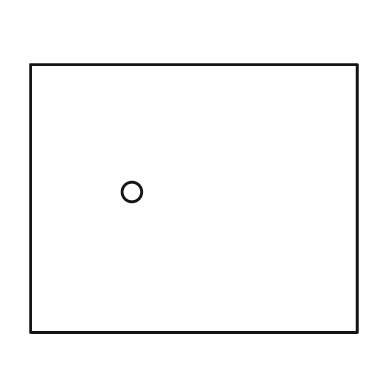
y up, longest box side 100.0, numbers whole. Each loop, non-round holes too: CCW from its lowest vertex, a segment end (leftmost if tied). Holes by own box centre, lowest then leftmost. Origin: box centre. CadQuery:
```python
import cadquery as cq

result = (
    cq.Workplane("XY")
    .moveTo(-50.0, -41.0)
    .lineTo(50.0, -41.0)
    .lineTo(50.0, 41.0)
    .lineTo(-50.0, 41.0)
    .close()
    .moveTo(-19.0, 2.0)
    .circle(3.0)
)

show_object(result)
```